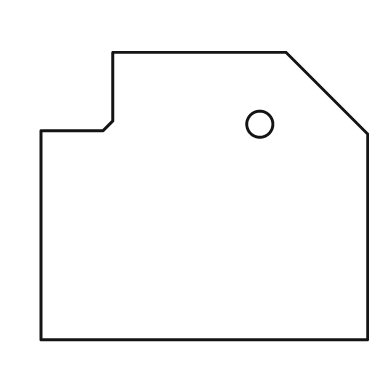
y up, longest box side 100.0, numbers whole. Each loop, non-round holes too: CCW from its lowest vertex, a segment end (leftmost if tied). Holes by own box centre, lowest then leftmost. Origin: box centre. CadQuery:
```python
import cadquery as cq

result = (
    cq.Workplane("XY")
    .moveTo(-50.0, -44.0)
    .lineTo(50.0, -44.0)
    .lineTo(50.0, 19.0)
    .lineTo(25.0, 44.0)
    .lineTo(-28.0, 44.0)
    .lineTo(-28.0, 23.0)
    .lineTo(-31.0, 20.0)
    .lineTo(-50.0, 20.0)
    .close()
    .moveTo(17.0, 22.0)
    .circle(4.0)
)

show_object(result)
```